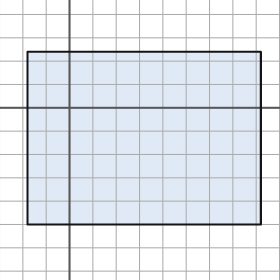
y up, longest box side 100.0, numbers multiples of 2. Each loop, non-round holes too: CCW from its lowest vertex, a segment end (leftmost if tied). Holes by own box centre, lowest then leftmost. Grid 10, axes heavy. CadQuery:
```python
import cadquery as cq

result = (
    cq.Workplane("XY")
    .moveTo(-18.0, -50.0)
    .lineTo(82.0, -50.0)
    .lineTo(82.0, 24.0)
    .lineTo(-18.0, 24.0)
    .close()
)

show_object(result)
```